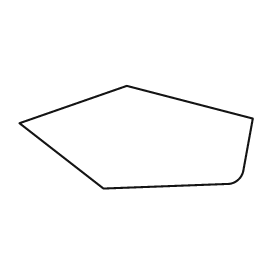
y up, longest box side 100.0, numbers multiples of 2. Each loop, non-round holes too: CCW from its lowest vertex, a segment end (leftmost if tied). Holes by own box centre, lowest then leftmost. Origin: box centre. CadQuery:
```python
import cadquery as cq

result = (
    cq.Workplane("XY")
    .moveTo(-14.0, -22.0)
    .lineTo(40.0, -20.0)
    .threePointArc((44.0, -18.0), (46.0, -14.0))
    .lineTo(50.0, 8.0)
    .lineTo(-4.0, 22.0)
    .lineTo(-50.0, 6.0)
    .close()
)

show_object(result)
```